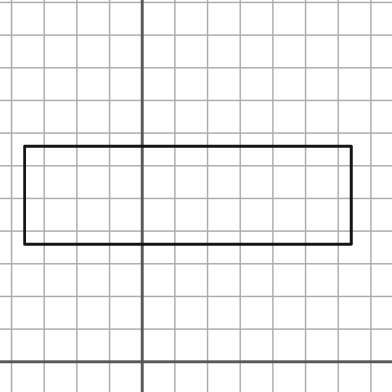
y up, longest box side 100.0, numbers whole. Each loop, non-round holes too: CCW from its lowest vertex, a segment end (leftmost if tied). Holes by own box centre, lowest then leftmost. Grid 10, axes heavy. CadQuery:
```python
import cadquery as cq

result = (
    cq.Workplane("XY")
    .moveTo(-36.0, 36.0)
    .lineTo(64.0, 36.0)
    .lineTo(64.0, 66.0)
    .lineTo(-36.0, 66.0)
    .close()
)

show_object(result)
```